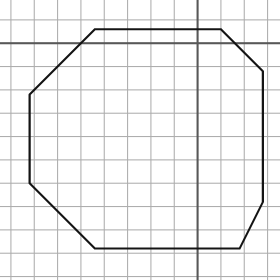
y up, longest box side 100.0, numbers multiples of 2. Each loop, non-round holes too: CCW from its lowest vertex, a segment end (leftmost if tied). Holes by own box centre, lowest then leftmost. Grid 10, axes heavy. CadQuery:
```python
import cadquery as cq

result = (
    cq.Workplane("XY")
    .moveTo(-44.0, -88.0)
    .lineTo(18.0, -88.0)
    .lineTo(28.0, -68.0)
    .lineTo(28.0, -12.0)
    .lineTo(10.0, 6.0)
    .lineTo(-44.0, 6.0)
    .lineTo(-72.0, -22.0)
    .lineTo(-72.0, -60.0)
    .close()
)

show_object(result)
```